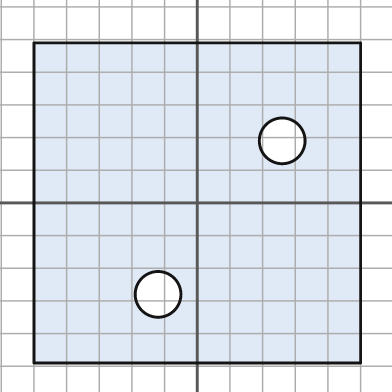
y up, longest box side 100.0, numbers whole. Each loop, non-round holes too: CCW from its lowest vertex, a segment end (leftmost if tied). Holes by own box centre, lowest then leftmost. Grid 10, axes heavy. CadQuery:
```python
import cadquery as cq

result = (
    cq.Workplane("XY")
    .moveTo(-50.0, -49.0)
    .lineTo(50.0, -49.0)
    .lineTo(50.0, 49.0)
    .lineTo(-50.0, 49.0)
    .close()
    .moveTo(-12.0, -28.0)
    .circle(7.0)
    .moveTo(26.0, 19.0)
    .circle(7.0)
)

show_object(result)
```